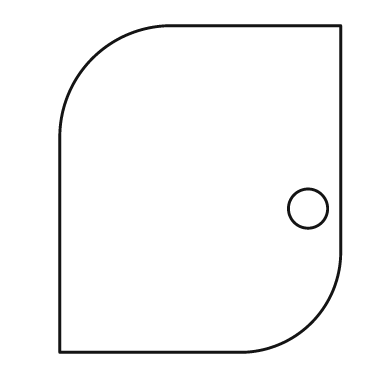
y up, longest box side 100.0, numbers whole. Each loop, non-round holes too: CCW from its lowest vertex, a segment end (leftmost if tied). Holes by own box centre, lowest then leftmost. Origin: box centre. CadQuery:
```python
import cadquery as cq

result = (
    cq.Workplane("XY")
    .moveTo(-43.0, -50.0)
    .lineTo(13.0, -50.0)
    .threePointArc((34.0, -41.0), (43.0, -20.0))
    .lineTo(43.0, 50.0)
    .lineTo(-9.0, 50.0)
    .threePointArc((-33.0, 40.0), (-43.0, 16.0))
    .close()
    .moveTo(33.0, -6.0)
    .circle(6.0)
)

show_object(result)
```